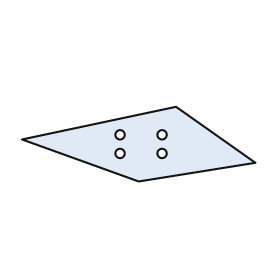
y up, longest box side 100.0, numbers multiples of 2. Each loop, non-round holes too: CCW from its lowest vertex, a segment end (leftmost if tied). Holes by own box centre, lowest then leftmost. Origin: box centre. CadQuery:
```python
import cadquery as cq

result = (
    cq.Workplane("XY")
    .moveTo(0.0, -16.0)
    .lineTo(50.0, -8.0)
    .lineTo(16.0, 16.0)
    .lineTo(-50.0, 2.0)
    .close()
    .moveTo(-8.0, -4.0)
    .circle(2.0)
    .moveTo(10.0, -4.0)
    .circle(2.0)
    .moveTo(-8.0, 4.0)
    .circle(2.0)
    .moveTo(10.0, 4.0)
    .circle(2.0)
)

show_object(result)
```